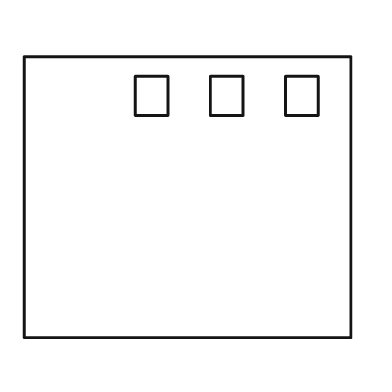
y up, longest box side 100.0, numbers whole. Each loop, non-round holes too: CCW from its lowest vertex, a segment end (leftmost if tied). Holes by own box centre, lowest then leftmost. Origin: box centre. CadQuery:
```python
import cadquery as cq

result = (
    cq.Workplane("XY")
    .moveTo(-50.0, -43.0)
    .lineTo(50.0, -43.0)
    .lineTo(50.0, 43.0)
    .lineTo(-50.0, 43.0)
    .close()
    .moveTo(-16.0, 25.0)
    .lineTo(-6.0, 25.0)
    .lineTo(-6.0, 37.0)
    .lineTo(-16.0, 37.0)
    .close()
    .moveTo(7.0, 25.0)
    .lineTo(17.0, 25.0)
    .lineTo(17.0, 37.0)
    .lineTo(7.0, 37.0)
    .close()
    .moveTo(30.0, 25.0)
    .lineTo(40.0, 25.0)
    .lineTo(40.0, 37.0)
    .lineTo(30.0, 37.0)
    .close()
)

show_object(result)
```